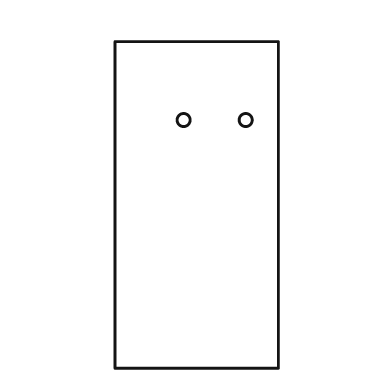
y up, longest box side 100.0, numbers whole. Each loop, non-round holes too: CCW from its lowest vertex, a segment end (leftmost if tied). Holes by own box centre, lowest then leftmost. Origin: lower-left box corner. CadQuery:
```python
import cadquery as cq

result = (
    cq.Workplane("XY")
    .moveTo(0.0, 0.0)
    .lineTo(50.0, 0.0)
    .lineTo(50.0, 100.0)
    .lineTo(0.0, 100.0)
    .close()
    .moveTo(21.0, 76.0)
    .circle(2.0)
    .moveTo(40.0, 76.0)
    .circle(2.0)
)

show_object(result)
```